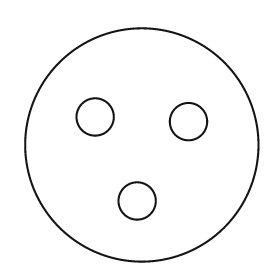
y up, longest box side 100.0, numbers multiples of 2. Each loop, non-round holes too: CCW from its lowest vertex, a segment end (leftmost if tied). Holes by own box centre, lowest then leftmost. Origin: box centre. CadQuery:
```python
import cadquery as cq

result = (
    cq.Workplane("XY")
    .moveTo(0.0, 0.0)
    .circle(50.0)
    .moveTo(-2.0, -24.0)
    .circle(8.0)
    .moveTo(20.0, 10.0)
    .circle(8.0)
    .moveTo(-20.0, 12.0)
    .circle(8.0)
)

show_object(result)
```